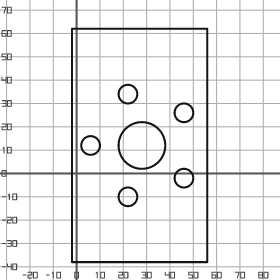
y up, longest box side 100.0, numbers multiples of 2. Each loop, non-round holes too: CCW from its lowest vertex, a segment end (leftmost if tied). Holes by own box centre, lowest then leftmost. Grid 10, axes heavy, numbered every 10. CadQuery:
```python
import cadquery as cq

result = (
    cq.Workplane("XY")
    .moveTo(-2.0, -38.0)
    .lineTo(56.0, -38.0)
    .lineTo(56.0, 62.0)
    .lineTo(-2.0, 62.0)
    .close()
    .moveTo(22.0, -10.0)
    .circle(4.0)
    .moveTo(46.0, -2.0)
    .circle(4.0)
    .moveTo(6.0, 12.0)
    .circle(4.0)
    .moveTo(28.0, 12.0)
    .circle(10.0)
    .moveTo(46.0, 26.0)
    .circle(4.0)
    .moveTo(22.0, 34.0)
    .circle(4.0)
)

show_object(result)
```